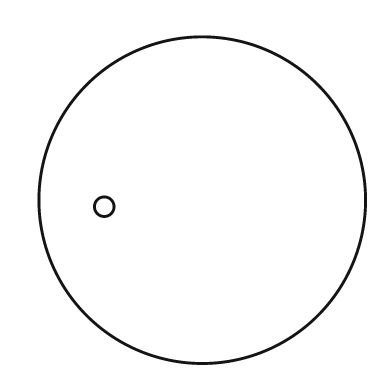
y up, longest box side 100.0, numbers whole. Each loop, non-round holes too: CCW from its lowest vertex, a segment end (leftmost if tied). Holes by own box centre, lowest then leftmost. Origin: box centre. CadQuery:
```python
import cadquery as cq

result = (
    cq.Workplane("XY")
    .moveTo(0.0, 0.0)
    .circle(50.0)
    .moveTo(-30.0, -2.0)
    .circle(3.0)
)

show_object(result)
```